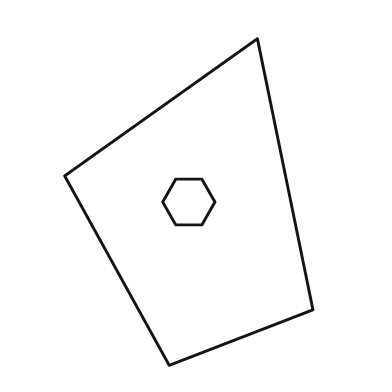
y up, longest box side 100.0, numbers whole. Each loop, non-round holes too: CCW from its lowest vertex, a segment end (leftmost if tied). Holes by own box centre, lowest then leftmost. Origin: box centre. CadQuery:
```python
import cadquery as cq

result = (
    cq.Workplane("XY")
    .moveTo(-6.0, -50.0)
    .lineTo(38.0, -33.0)
    .lineTo(21.0, 50.0)
    .lineTo(-38.0, 8.0)
    .close()
    .moveTo(-4.0, -7.0)
    .lineTo(4.0, -7.0)
    .lineTo(8.0, 0.0)
    .lineTo(4.0, 7.0)
    .lineTo(-4.0, 7.0)
    .lineTo(-8.0, 0.0)
    .close()
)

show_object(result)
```